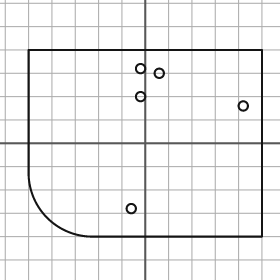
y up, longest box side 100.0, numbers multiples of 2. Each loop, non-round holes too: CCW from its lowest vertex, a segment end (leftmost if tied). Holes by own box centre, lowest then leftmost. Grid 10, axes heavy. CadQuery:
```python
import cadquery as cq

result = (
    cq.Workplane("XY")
    .moveTo(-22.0, -40.0)
    .lineTo(50.0, -40.0)
    .lineTo(50.0, 40.0)
    .lineTo(-50.0, 40.0)
    .lineTo(-50.0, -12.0)
    .threePointArc((-42.0, -32.0), (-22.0, -40.0))
    .close()
    .moveTo(-6.0, -28.0)
    .circle(2.0)
    .moveTo(42.0, 16.0)
    .circle(2.0)
    .moveTo(-2.0, 20.0)
    .circle(2.0)
    .moveTo(6.0, 30.0)
    .circle(2.0)
    .moveTo(-2.0, 32.0)
    .circle(2.0)
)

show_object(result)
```